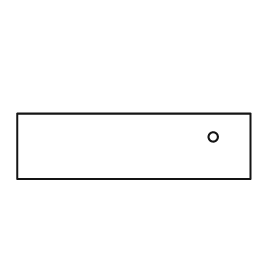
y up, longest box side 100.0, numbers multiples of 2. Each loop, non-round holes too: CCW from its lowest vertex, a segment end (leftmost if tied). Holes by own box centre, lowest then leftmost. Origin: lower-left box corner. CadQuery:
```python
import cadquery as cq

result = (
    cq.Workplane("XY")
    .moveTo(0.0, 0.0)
    .lineTo(100.0, 0.0)
    .lineTo(100.0, 28.0)
    .lineTo(0.0, 28.0)
    .close()
    .moveTo(84.0, 18.0)
    .circle(2.0)
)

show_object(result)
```